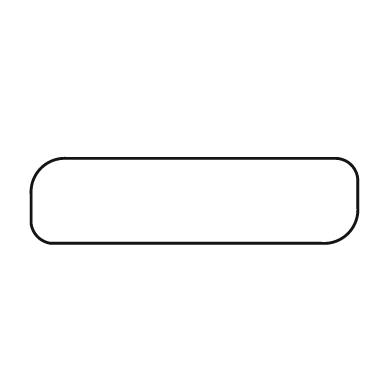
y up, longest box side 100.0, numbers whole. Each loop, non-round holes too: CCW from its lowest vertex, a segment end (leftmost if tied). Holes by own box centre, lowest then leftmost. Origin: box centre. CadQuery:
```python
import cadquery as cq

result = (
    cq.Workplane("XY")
    .moveTo(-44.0, -13.0)
    .lineTo(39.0, -13.0)
    .threePointArc((47.0, -10.0), (50.0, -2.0))
    .lineTo(50.0, 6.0)
    .threePointArc((48.0, 11.0), (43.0, 13.0))
    .lineTo(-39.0, 13.0)
    .threePointArc((-47.0, 10.0), (-50.0, 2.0))
    .lineTo(-50.0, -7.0)
    .threePointArc((-48.0, -11.0), (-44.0, -13.0))
    .close()
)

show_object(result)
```